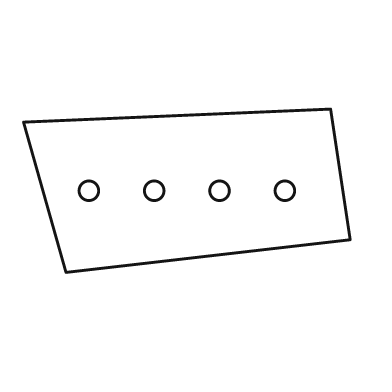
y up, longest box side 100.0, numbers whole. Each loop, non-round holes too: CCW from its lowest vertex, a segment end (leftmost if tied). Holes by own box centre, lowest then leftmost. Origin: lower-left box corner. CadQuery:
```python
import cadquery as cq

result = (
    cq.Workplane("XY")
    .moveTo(13.0, 0.0)
    .lineTo(100.0, 10.0)
    .lineTo(94.0, 50.0)
    .lineTo(0.0, 46.0)
    .close()
    .moveTo(20.0, 25.0)
    .circle(3.0)
    .moveTo(40.0, 25.0)
    .circle(3.0)
    .moveTo(60.0, 25.0)
    .circle(3.0)
    .moveTo(80.0, 25.0)
    .circle(3.0)
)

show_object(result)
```